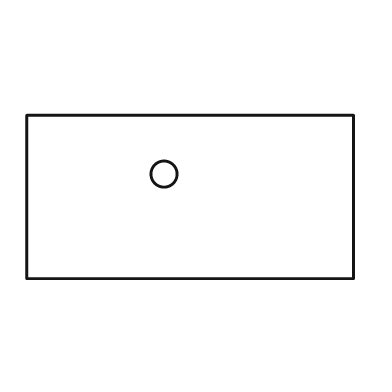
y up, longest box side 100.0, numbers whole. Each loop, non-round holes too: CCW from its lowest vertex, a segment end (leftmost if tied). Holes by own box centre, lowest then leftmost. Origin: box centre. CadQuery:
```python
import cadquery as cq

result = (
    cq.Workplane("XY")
    .moveTo(-50.0, -25.0)
    .lineTo(50.0, -25.0)
    .lineTo(50.0, 25.0)
    .lineTo(-50.0, 25.0)
    .close()
    .moveTo(-8.0, 7.0)
    .circle(4.0)
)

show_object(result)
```